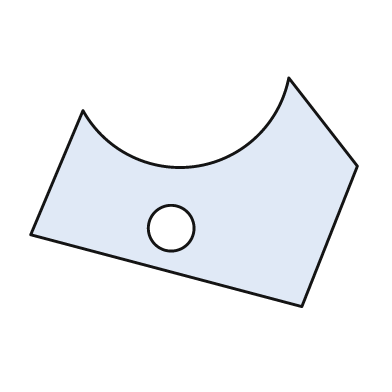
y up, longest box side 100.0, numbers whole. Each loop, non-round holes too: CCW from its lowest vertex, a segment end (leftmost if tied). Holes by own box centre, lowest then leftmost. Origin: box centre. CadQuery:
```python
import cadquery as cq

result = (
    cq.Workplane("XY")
    .moveTo(33.0, -35.0)
    .lineTo(50.0, 8.0)
    .lineTo(29.0, 35.0)
    .threePointArc((1.0, 8.0), (-34.0, 25.0))
    .lineTo(-50.0, -13.0)
    .close()
    .moveTo(-7.0, -11.0)
    .circle(7.0)
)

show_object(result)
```